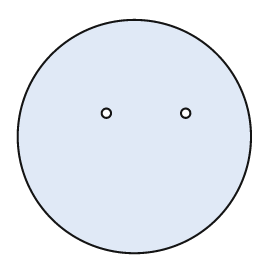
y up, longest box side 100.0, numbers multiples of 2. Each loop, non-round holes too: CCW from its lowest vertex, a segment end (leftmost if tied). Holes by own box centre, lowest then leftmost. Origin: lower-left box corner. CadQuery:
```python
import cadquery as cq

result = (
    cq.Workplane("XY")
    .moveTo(50.0, 50.0)
    .circle(50.0)
    .moveTo(38.0, 60.0)
    .circle(2.0)
    .moveTo(72.0, 60.0)
    .circle(2.0)
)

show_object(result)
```